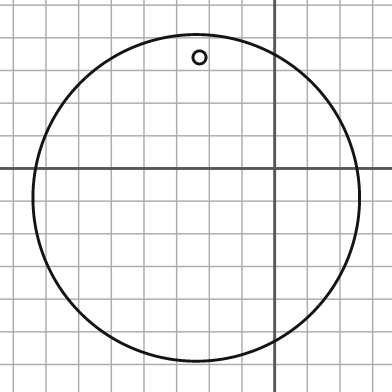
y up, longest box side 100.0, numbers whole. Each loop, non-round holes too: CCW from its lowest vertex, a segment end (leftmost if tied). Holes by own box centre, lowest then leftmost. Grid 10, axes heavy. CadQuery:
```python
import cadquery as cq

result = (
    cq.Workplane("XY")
    .moveTo(-24.0, -9.0)
    .circle(50.0)
    .moveTo(-23.0, 34.0)
    .circle(2.0)
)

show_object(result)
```